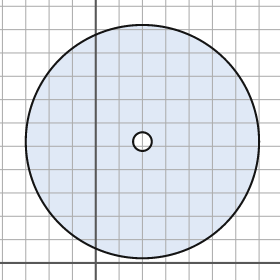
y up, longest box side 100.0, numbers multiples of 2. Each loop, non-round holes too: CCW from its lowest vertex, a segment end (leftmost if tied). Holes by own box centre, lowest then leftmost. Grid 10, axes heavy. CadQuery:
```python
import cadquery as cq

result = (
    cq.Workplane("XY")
    .moveTo(20.0, 52.0)
    .circle(50.0)
    .moveTo(20.0, 52.0)
    .circle(4.0)
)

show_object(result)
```